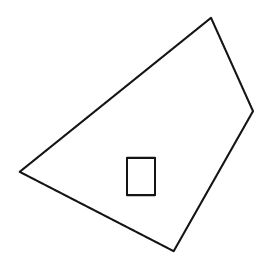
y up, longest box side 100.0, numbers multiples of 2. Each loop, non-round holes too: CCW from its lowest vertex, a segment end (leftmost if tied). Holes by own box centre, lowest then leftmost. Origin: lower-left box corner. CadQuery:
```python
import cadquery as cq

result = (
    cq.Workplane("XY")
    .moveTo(66.0, 0.0)
    .lineTo(100.0, 60.0)
    .lineTo(82.0, 100.0)
    .lineTo(0.0, 34.0)
    .close()
    .moveTo(46.0, 24.0)
    .lineTo(58.0, 24.0)
    .lineTo(58.0, 40.0)
    .lineTo(46.0, 40.0)
    .close()
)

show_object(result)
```